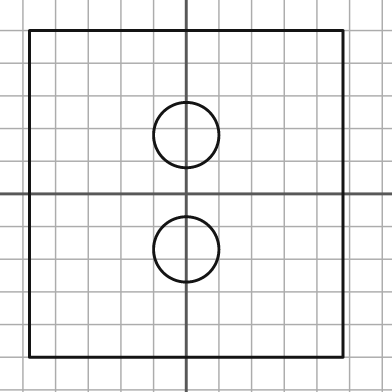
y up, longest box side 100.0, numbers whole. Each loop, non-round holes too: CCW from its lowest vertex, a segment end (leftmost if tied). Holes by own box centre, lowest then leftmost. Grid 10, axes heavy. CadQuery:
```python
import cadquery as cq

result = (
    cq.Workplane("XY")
    .moveTo(-48.0, -50.0)
    .lineTo(48.0, -50.0)
    .lineTo(48.0, 50.0)
    .lineTo(-48.0, 50.0)
    .close()
    .moveTo(0.0, -17.0)
    .circle(10.0)
    .moveTo(0.0, 18.0)
    .circle(10.0)
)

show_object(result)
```